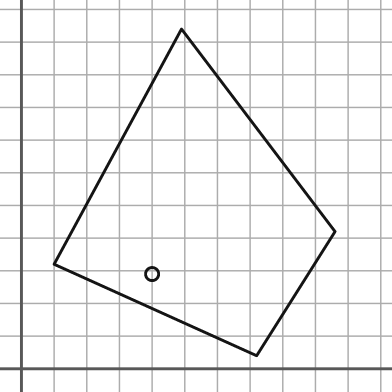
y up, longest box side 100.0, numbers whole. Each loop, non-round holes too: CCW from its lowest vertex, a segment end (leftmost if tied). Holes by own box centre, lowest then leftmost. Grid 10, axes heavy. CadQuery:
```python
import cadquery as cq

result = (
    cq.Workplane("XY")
    .moveTo(72.0, 4.0)
    .lineTo(96.0, 42.0)
    .lineTo(49.0, 104.0)
    .lineTo(10.0, 32.0)
    .close()
    .moveTo(40.0, 29.0)
    .circle(2.0)
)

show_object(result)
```